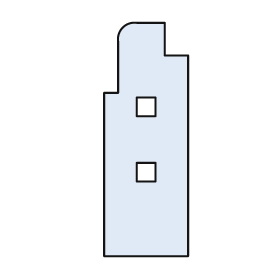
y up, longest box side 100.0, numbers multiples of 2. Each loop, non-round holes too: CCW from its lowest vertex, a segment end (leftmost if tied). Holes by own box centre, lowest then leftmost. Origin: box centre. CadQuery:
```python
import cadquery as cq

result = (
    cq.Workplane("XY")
    .moveTo(-18.0, -50.0)
    .lineTo(18.0, -50.0)
    .lineTo(18.0, 36.0)
    .lineTo(8.0, 36.0)
    .lineTo(8.0, 50.0)
    .lineTo(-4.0, 50.0)
    .threePointArc((-10.0, 48.0), (-12.0, 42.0))
    .lineTo(-12.0, 20.0)
    .lineTo(-18.0, 20.0)
    .close()
    .moveTo(-4.0, -18.0)
    .lineTo(4.0, -18.0)
    .lineTo(4.0, -10.0)
    .lineTo(-4.0, -10.0)
    .close()
    .moveTo(-4.0, 10.0)
    .lineTo(4.0, 10.0)
    .lineTo(4.0, 18.0)
    .lineTo(-4.0, 18.0)
    .close()
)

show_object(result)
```